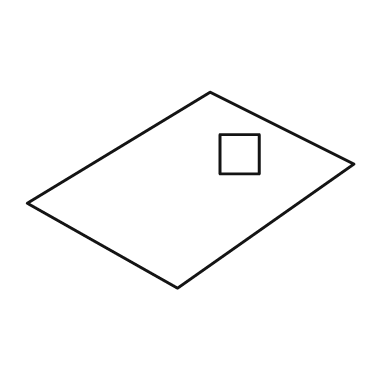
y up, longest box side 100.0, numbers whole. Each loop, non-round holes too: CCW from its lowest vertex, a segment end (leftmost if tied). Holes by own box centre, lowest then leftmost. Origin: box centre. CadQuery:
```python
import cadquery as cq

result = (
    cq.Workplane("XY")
    .moveTo(-4.0, -30.0)
    .lineTo(50.0, 8.0)
    .lineTo(6.0, 30.0)
    .lineTo(-50.0, -4.0)
    .close()
    .moveTo(9.0, 5.0)
    .lineTo(21.0, 5.0)
    .lineTo(21.0, 17.0)
    .lineTo(9.0, 17.0)
    .close()
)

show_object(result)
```